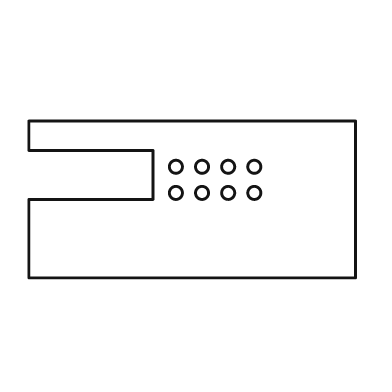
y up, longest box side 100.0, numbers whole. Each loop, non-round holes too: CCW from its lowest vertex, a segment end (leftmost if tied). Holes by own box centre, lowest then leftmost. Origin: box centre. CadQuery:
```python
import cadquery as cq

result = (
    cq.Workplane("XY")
    .moveTo(-50.0, -24.0)
    .lineTo(50.0, -24.0)
    .lineTo(50.0, 24.0)
    .lineTo(-50.0, 24.0)
    .lineTo(-50.0, 15.0)
    .lineTo(-12.0, 15.0)
    .lineTo(-12.0, 0.0)
    .lineTo(-50.0, 0.0)
    .close()
    .moveTo(-5.0, 2.0)
    .circle(2.0)
    .moveTo(3.0, 2.0)
    .circle(2.0)
    .moveTo(11.0, 2.0)
    .circle(2.0)
    .moveTo(19.0, 2.0)
    .circle(2.0)
    .moveTo(-5.0, 10.0)
    .circle(2.0)
    .moveTo(3.0, 10.0)
    .circle(2.0)
    .moveTo(11.0, 10.0)
    .circle(2.0)
    .moveTo(19.0, 10.0)
    .circle(2.0)
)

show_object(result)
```